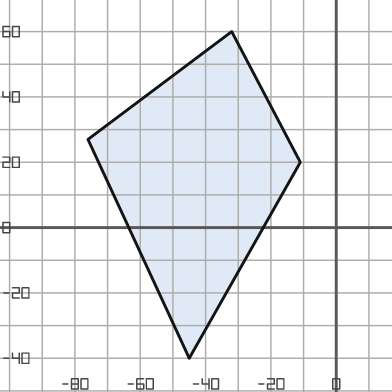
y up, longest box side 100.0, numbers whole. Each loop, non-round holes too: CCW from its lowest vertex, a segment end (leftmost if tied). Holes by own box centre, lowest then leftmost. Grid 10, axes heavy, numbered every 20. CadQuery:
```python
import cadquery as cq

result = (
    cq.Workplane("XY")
    .moveTo(-45.0, -40.0)
    .lineTo(-11.0, 20.0)
    .lineTo(-32.0, 60.0)
    .lineTo(-76.0, 27.0)
    .close()
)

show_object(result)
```